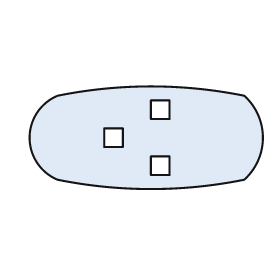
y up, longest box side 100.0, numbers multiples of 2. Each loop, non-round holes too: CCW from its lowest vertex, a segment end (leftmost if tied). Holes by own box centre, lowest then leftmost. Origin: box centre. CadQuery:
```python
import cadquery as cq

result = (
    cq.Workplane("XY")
    .moveTo(-38.0, -18.0)
    .threePointArc((2.0, -22.0), (42.0, -18.0))
    .threePointArc((50.0, 0.0), (42.0, 18.0))
    .threePointArc((2.0, 22.0), (-38.0, 18.0))
    .threePointArc((-50.0, 0.0), (-38.0, -18.0))
    .close()
    .moveTo(2.0, -16.0)
    .lineTo(10.0, -16.0)
    .lineTo(10.0, -8.0)
    .lineTo(2.0, -8.0)
    .close()
    .moveTo(-18.0, -4.0)
    .lineTo(-10.0, -4.0)
    .lineTo(-10.0, 4.0)
    .lineTo(-18.0, 4.0)
    .close()
    .moveTo(2.0, 8.0)
    .lineTo(10.0, 8.0)
    .lineTo(10.0, 16.0)
    .lineTo(2.0, 16.0)
    .close()
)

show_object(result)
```